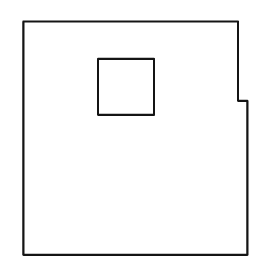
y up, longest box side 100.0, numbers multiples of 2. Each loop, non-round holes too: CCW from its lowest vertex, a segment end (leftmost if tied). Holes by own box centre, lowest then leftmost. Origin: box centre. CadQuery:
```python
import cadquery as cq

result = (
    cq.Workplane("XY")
    .moveTo(-48.0, -50.0)
    .lineTo(48.0, -50.0)
    .lineTo(48.0, 16.0)
    .lineTo(44.0, 16.0)
    .lineTo(44.0, 50.0)
    .lineTo(-48.0, 50.0)
    .close()
    .moveTo(-16.0, 10.0)
    .lineTo(8.0, 10.0)
    .lineTo(8.0, 34.0)
    .lineTo(-16.0, 34.0)
    .close()
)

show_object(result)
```